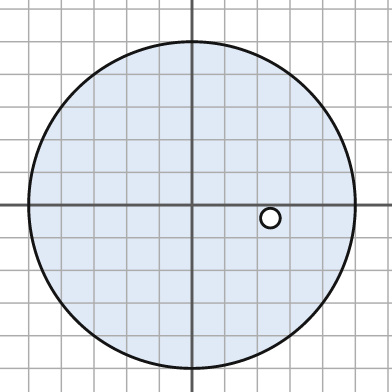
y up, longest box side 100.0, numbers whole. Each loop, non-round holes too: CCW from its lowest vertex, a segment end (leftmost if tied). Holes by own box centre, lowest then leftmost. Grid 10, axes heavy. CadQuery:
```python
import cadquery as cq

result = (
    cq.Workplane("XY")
    .moveTo(0.0, 0.0)
    .circle(50.0)
    .moveTo(24.0, -4.0)
    .circle(3.0)
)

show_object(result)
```